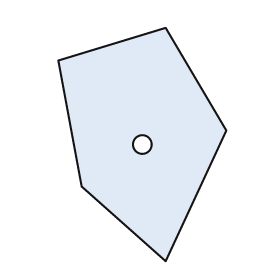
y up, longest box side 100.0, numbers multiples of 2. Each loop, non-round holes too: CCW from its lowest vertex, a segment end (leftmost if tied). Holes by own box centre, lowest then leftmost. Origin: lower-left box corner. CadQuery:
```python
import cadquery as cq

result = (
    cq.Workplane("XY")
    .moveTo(46.0, 0.0)
    .lineTo(72.0, 56.0)
    .lineTo(46.0, 100.0)
    .lineTo(0.0, 86.0)
    .lineTo(10.0, 32.0)
    .close()
    .moveTo(36.0, 50.0)
    .circle(4.0)
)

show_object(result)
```